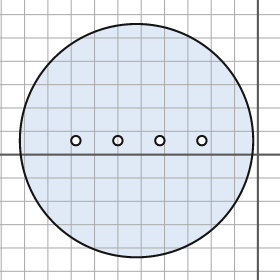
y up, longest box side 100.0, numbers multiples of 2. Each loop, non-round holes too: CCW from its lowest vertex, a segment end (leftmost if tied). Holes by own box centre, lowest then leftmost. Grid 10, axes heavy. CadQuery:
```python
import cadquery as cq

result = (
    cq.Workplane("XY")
    .moveTo(-52.0, 6.0)
    .circle(50.0)
    .moveTo(-78.0, 6.0)
    .circle(2.0)
    .moveTo(-60.0, 6.0)
    .circle(2.0)
    .moveTo(-42.0, 6.0)
    .circle(2.0)
    .moveTo(-24.0, 6.0)
    .circle(2.0)
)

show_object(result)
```